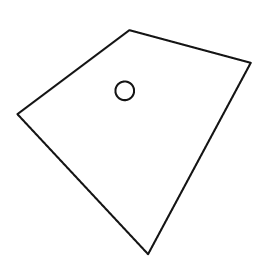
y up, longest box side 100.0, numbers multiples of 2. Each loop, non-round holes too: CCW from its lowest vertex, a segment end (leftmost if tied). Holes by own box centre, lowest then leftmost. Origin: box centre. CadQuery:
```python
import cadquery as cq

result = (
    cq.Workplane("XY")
    .moveTo(6.0, -48.0)
    .lineTo(50.0, 34.0)
    .lineTo(-2.0, 48.0)
    .lineTo(-50.0, 12.0)
    .close()
    .moveTo(-4.0, 22.0)
    .circle(4.0)
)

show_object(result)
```